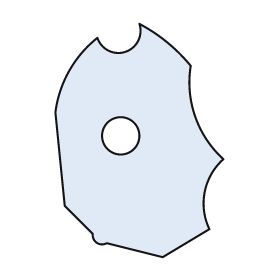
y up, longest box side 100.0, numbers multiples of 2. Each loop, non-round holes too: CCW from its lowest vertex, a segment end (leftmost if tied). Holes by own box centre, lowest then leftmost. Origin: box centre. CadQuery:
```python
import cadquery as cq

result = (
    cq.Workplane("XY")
    .moveTo(10.0, -50.0)
    .lineTo(30.0, -38.0)
    .threePointArc((28.0, -22.0), (36.0, -8.0))
    .threePointArc((24.0, 10.0), (22.0, 32.0))
    .threePointArc((12.0, 42.0), (0.0, 50.0))
    .threePointArc((-6.0, 38.0), (-18.0, 44.0))
    .threePointArc((-30.0, 30.0), (-36.0, 12.0))
    .lineTo(-32.0, -28.0)
    .lineTo(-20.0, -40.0)
    .threePointArc((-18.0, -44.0), (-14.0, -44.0))
    .close()
    .moveTo(-8.0, 2.0)
    .circle(8.0)
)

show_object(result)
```